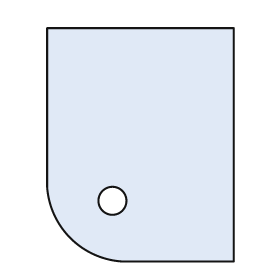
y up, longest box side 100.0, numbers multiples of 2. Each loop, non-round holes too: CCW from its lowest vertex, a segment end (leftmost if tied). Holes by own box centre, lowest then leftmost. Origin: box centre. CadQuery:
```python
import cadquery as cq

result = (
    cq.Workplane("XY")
    .moveTo(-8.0, -50.0)
    .lineTo(40.0, -50.0)
    .lineTo(40.0, 50.0)
    .lineTo(-40.0, 50.0)
    .lineTo(-40.0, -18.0)
    .threePointArc((-30.0, -40.0), (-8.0, -50.0))
    .close()
    .moveTo(-12.0, -24.0)
    .circle(6.0)
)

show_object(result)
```